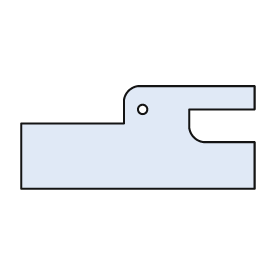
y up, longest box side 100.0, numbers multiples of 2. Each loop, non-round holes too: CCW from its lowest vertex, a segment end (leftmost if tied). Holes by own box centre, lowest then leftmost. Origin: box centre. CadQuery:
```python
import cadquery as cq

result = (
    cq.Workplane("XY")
    .moveTo(-50.0, -22.0)
    .lineTo(50.0, -22.0)
    .lineTo(50.0, -2.0)
    .lineTo(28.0, -2.0)
    .threePointArc((24.0, 0.0), (22.0, 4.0))
    .lineTo(22.0, 12.0)
    .lineTo(50.0, 12.0)
    .lineTo(50.0, 22.0)
    .lineTo(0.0, 22.0)
    .threePointArc((-4.0, 20.0), (-6.0, 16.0))
    .lineTo(-6.0, 6.0)
    .lineTo(-50.0, 6.0)
    .close()
    .moveTo(2.0, 12.0)
    .circle(2.0)
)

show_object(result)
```